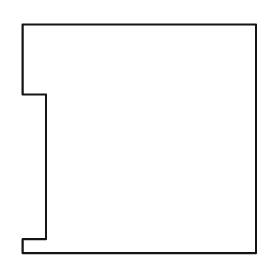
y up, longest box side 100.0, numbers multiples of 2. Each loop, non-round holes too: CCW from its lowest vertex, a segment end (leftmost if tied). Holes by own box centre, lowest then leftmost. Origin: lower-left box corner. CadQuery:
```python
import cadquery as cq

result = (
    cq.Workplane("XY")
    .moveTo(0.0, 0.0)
    .lineTo(100.0, 0.0)
    .lineTo(100.0, 98.0)
    .lineTo(0.0, 98.0)
    .lineTo(0.0, 68.0)
    .lineTo(10.0, 68.0)
    .lineTo(10.0, 6.0)
    .lineTo(0.0, 6.0)
    .close()
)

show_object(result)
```